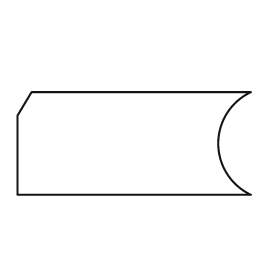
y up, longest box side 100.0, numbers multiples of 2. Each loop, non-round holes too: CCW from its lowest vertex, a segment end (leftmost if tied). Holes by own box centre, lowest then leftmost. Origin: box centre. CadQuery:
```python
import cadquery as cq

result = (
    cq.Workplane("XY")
    .moveTo(-50.0, -22.0)
    .lineTo(50.0, -22.0)
    .threePointArc((36.0, 0.0), (50.0, 22.0))
    .lineTo(-44.0, 22.0)
    .lineTo(-50.0, 12.0)
    .close()
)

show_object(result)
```